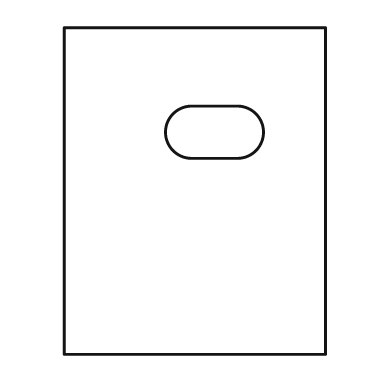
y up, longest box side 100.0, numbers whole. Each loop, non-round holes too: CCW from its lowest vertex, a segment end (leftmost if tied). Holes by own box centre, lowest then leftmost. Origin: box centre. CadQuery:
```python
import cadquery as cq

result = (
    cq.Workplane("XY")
    .moveTo(-40.0, -50.0)
    .lineTo(40.0, -50.0)
    .lineTo(40.0, 50.0)
    .lineTo(-40.0, 50.0)
    .close()
    .moveTo(-1.0, 10.0)
    .lineTo(13.0, 10.0)
    .threePointArc((21.0, 18.0), (13.0, 26.0))
    .lineTo(-1.0, 26.0)
    .threePointArc((-9.0, 18.0), (-1.0, 10.0))
    .close()
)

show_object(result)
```